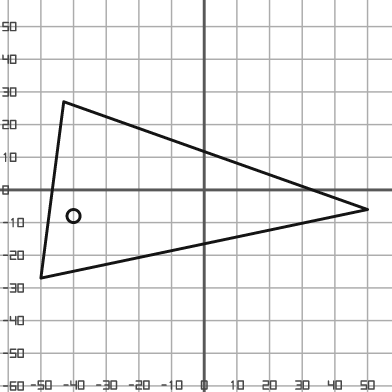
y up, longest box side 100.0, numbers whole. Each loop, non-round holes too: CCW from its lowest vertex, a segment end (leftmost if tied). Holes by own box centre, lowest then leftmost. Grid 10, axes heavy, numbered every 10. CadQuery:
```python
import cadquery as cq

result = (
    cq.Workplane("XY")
    .moveTo(-50.0, -27.0)
    .lineTo(50.0, -6.0)
    .lineTo(-43.0, 27.0)
    .close()
    .moveTo(-40.0, -8.0)
    .circle(2.0)
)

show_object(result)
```